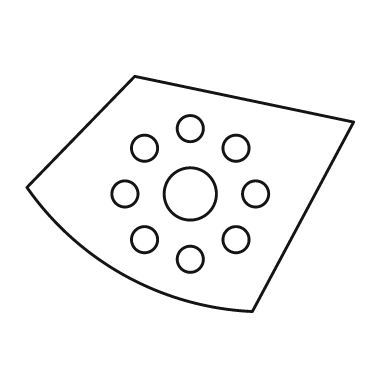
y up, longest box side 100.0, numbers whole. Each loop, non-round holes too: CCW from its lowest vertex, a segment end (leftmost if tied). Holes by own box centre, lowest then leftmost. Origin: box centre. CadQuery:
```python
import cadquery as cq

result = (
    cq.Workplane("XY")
    .moveTo(19.0, -36.0)
    .lineTo(50.0, 22.0)
    .lineTo(-17.0, 36.0)
    .lineTo(-50.0, 2.0)
    .threePointArc((-20.0, -25.0), (19.0, -36.0))
    .close()
    .moveTo(0.0, -20.0)
    .circle(4.0)
    .moveTo(-14.0, -14.0)
    .circle(4.0)
    .moveTo(14.0, -14.0)
    .circle(4.0)
    .moveTo(-20.0, 0.0)
    .circle(4.0)
    .moveTo(0.0, 0.0)
    .circle(8.0)
    .moveTo(20.0, 0.0)
    .circle(4.0)
    .moveTo(-14.0, 14.0)
    .circle(4.0)
    .moveTo(14.0, 14.0)
    .circle(4.0)
    .moveTo(0.0, 20.0)
    .circle(4.0)
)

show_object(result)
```